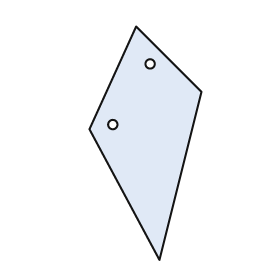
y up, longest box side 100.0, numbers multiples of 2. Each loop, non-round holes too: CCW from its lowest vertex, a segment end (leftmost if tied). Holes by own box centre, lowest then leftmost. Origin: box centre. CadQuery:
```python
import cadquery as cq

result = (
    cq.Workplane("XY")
    .moveTo(6.0, -50.0)
    .lineTo(24.0, 22.0)
    .lineTo(-4.0, 50.0)
    .lineTo(-24.0, 6.0)
    .close()
    .moveTo(-14.0, 8.0)
    .circle(2.0)
    .moveTo(2.0, 34.0)
    .circle(2.0)
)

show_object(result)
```